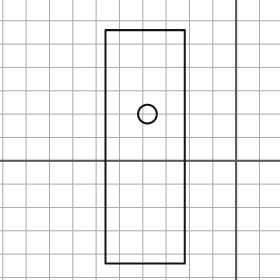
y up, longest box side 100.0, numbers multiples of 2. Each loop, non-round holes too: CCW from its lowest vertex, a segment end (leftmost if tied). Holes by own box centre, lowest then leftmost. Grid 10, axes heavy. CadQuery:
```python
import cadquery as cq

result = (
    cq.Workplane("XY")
    .moveTo(-56.0, -44.0)
    .lineTo(-22.0, -44.0)
    .lineTo(-22.0, 56.0)
    .lineTo(-56.0, 56.0)
    .close()
    .moveTo(-38.0, 20.0)
    .circle(4.0)
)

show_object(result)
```